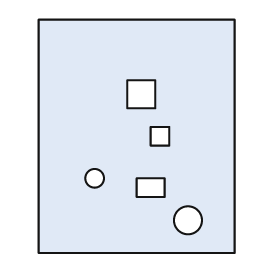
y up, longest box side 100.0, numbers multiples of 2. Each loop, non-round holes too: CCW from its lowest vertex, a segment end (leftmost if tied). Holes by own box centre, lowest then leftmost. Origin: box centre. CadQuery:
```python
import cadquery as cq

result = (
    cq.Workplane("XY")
    .moveTo(-42.0, -50.0)
    .lineTo(42.0, -50.0)
    .lineTo(42.0, 50.0)
    .lineTo(-42.0, 50.0)
    .close()
    .moveTo(22.0, -36.0)
    .circle(6.0)
    .moveTo(0.0, -26.0)
    .lineTo(12.0, -26.0)
    .lineTo(12.0, -18.0)
    .lineTo(0.0, -18.0)
    .close()
    .moveTo(-18.0, -18.0)
    .circle(4.0)
    .moveTo(6.0, -4.0)
    .lineTo(14.0, -4.0)
    .lineTo(14.0, 4.0)
    .lineTo(6.0, 4.0)
    .close()
    .moveTo(-4.0, 12.0)
    .lineTo(8.0, 12.0)
    .lineTo(8.0, 24.0)
    .lineTo(-4.0, 24.0)
    .close()
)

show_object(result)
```